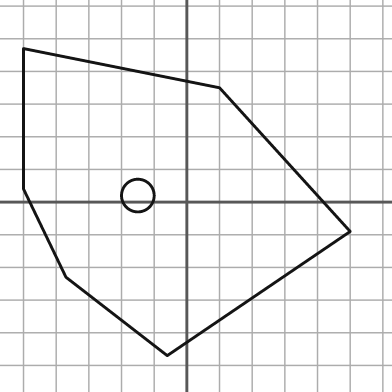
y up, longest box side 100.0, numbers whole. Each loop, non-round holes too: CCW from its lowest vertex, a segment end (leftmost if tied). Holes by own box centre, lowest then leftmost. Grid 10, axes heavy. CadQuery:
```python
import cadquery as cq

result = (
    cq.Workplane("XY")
    .moveTo(-6.0, -47.0)
    .lineTo(50.0, -9.0)
    .lineTo(10.0, 35.0)
    .lineTo(-50.0, 47.0)
    .lineTo(-50.0, 4.0)
    .lineTo(-37.0, -23.0)
    .close()
    .moveTo(-15.0, 2.0)
    .circle(5.0)
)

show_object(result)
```